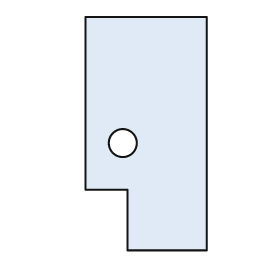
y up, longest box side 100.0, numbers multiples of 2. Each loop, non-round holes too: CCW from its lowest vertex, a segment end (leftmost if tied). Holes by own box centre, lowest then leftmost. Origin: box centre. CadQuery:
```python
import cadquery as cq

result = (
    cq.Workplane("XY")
    .moveTo(-8.0, -50.0)
    .lineTo(26.0, -50.0)
    .lineTo(26.0, 50.0)
    .lineTo(-26.0, 50.0)
    .lineTo(-26.0, -24.0)
    .lineTo(-8.0, -24.0)
    .close()
    .moveTo(-10.0, -4.0)
    .circle(6.0)
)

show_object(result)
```